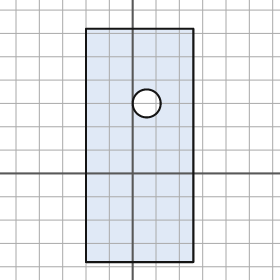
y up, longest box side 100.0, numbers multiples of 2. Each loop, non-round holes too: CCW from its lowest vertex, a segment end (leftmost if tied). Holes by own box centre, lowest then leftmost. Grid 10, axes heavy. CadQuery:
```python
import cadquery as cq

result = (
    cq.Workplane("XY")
    .moveTo(-20.0, -38.0)
    .lineTo(26.0, -38.0)
    .lineTo(26.0, 62.0)
    .lineTo(-20.0, 62.0)
    .close()
    .moveTo(6.0, 30.0)
    .circle(6.0)
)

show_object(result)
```